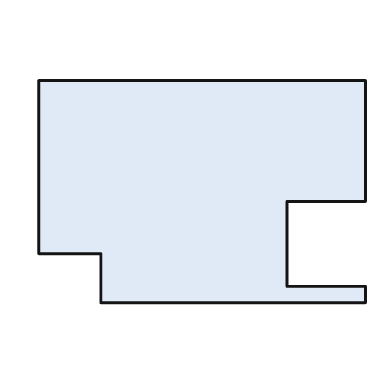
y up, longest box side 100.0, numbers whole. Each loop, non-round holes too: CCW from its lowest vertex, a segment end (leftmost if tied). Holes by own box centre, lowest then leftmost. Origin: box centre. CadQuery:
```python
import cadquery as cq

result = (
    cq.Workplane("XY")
    .moveTo(-31.0, -34.0)
    .lineTo(50.0, -34.0)
    .lineTo(50.0, -29.0)
    .lineTo(26.0, -29.0)
    .lineTo(26.0, -3.0)
    .lineTo(50.0, -3.0)
    .lineTo(50.0, 34.0)
    .lineTo(-50.0, 34.0)
    .lineTo(-50.0, -19.0)
    .lineTo(-31.0, -19.0)
    .close()
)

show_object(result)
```